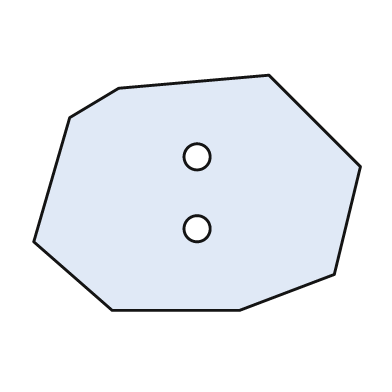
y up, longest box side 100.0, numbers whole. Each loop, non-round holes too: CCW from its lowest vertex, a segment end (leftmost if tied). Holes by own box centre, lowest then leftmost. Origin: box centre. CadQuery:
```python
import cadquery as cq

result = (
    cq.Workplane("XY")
    .moveTo(-26.0, -36.0)
    .lineTo(13.0, -36.0)
    .lineTo(42.0, -25.0)
    .lineTo(50.0, 8.0)
    .lineTo(22.0, 36.0)
    .lineTo(-24.0, 32.0)
    .lineTo(-39.0, 23.0)
    .lineTo(-50.0, -15.0)
    .close()
    .moveTo(0.0, -11.0)
    .circle(4.0)
    .moveTo(0.0, 11.0)
    .circle(4.0)
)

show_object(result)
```